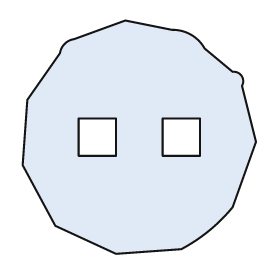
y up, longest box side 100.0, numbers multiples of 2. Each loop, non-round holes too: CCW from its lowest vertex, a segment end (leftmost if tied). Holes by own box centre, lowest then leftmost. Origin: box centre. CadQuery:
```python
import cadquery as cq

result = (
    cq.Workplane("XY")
    .moveTo(-10.0, -50.0)
    .lineTo(18.0, -48.0)
    .threePointArc((30.0, -40.0), (40.0, -30.0))
    .lineTo(50.0, -2.0)
    .lineTo(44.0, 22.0)
    .threePointArc((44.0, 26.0), (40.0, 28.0))
    .lineTo(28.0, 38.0)
    .threePointArc((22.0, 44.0), (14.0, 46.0))
    .lineTo(-6.0, 50.0)
    .lineTo(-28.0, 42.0)
    .threePointArc((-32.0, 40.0), (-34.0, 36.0))
    .lineTo(-48.0, 16.0)
    .lineTo(-50.0, -12.0)
    .lineTo(-36.0, -38.0)
    .close()
    .moveTo(-26.0, -8.0)
    .lineTo(-10.0, -8.0)
    .lineTo(-10.0, 8.0)
    .lineTo(-26.0, 8.0)
    .close()
    .moveTo(10.0, -8.0)
    .lineTo(26.0, -8.0)
    .lineTo(26.0, 8.0)
    .lineTo(10.0, 8.0)
    .close()
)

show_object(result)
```